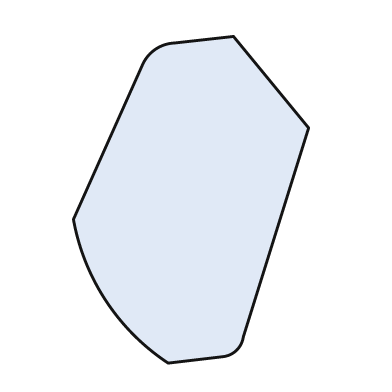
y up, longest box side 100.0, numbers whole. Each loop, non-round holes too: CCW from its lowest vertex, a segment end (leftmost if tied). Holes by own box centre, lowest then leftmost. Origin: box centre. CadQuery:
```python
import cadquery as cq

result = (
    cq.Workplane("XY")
    .moveTo(-7.0, -50.0)
    .lineTo(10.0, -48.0)
    .threePointArc((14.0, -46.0), (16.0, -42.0))
    .lineTo(36.0, 22.0)
    .lineTo(13.0, 50.0)
    .lineTo(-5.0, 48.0)
    .threePointArc((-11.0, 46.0), (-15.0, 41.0))
    .lineTo(-36.0, -6.0)
    .threePointArc((-26.0, -31.0), (-7.0, -50.0))
    .close()
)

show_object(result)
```